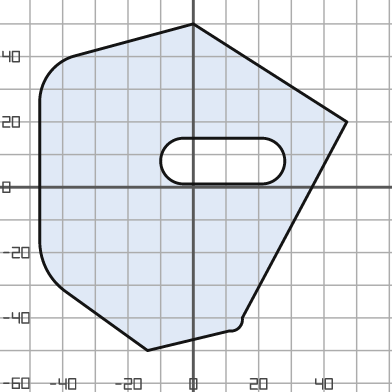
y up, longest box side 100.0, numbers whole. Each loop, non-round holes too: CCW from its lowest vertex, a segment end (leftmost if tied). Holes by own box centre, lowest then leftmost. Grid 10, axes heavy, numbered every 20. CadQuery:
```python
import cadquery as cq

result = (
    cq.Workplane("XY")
    .moveTo(-14.0, -50.0)
    .lineTo(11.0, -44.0)
    .threePointArc((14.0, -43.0), (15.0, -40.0))
    .lineTo(47.0, 20.0)
    .lineTo(0.0, 50.0)
    .lineTo(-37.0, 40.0)
    .threePointArc((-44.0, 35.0), (-47.0, 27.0))
    .lineTo(-47.0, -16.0)
    .threePointArc((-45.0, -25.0), (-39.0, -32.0))
    .close()
    .moveTo(-3.0, 1.0)
    .lineTo(21.0, 1.0)
    .threePointArc((28.0, 8.0), (21.0, 15.0))
    .lineTo(-3.0, 15.0)
    .threePointArc((-10.0, 8.0), (-3.0, 1.0))
    .close()
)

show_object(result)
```